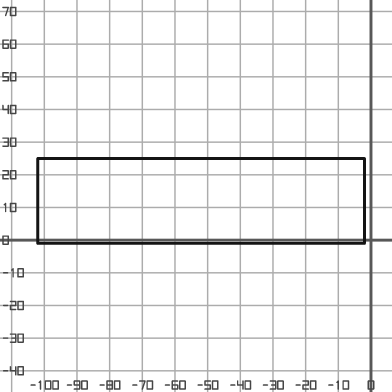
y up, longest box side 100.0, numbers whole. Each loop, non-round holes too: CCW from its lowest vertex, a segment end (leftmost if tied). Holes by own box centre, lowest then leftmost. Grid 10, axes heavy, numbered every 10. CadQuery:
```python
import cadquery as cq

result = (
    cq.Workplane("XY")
    .moveTo(-102.0, -1.0)
    .lineTo(-2.0, -1.0)
    .lineTo(-2.0, 25.0)
    .lineTo(-102.0, 25.0)
    .close()
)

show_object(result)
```